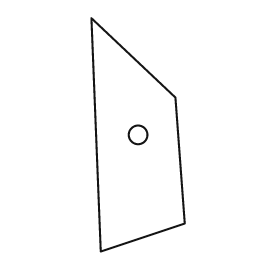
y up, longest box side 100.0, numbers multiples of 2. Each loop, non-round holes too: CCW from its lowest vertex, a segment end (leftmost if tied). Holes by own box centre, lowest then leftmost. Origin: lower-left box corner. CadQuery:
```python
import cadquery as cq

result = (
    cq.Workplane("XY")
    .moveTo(4.0, 0.0)
    .lineTo(40.0, 12.0)
    .lineTo(36.0, 66.0)
    .lineTo(0.0, 100.0)
    .close()
    .moveTo(20.0, 50.0)
    .circle(4.0)
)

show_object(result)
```